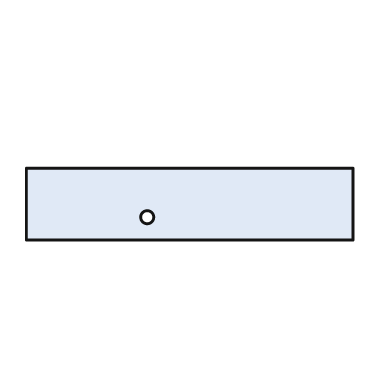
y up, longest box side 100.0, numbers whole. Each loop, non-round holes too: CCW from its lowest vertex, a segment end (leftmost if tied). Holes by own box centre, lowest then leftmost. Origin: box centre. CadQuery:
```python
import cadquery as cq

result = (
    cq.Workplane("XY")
    .moveTo(-50.0, -11.0)
    .lineTo(50.0, -11.0)
    .lineTo(50.0, 11.0)
    .lineTo(-50.0, 11.0)
    .close()
    .moveTo(-13.0, -4.0)
    .circle(2.0)
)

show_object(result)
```